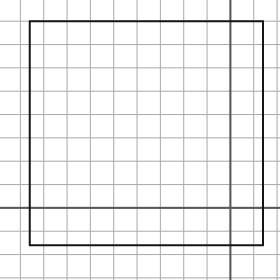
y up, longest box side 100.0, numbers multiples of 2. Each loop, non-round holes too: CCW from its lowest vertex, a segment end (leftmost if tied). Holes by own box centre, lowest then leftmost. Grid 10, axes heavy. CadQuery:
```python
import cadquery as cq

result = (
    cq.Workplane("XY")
    .moveTo(-86.0, -16.0)
    .lineTo(14.0, -16.0)
    .lineTo(14.0, 80.0)
    .lineTo(-86.0, 80.0)
    .close()
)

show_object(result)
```